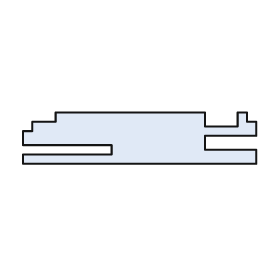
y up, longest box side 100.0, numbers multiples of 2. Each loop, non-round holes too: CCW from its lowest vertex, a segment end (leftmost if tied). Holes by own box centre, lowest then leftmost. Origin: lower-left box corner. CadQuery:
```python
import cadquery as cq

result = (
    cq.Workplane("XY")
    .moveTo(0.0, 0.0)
    .lineTo(100.0, 0.0)
    .lineTo(100.0, 6.0)
    .lineTo(78.0, 6.0)
    .lineTo(78.0, 12.0)
    .lineTo(100.0, 12.0)
    .lineTo(100.0, 18.0)
    .lineTo(96.0, 18.0)
    .lineTo(96.0, 22.0)
    .lineTo(92.0, 22.0)
    .lineTo(92.0, 16.0)
    .lineTo(78.0, 16.0)
    .lineTo(78.0, 22.0)
    .lineTo(14.0, 22.0)
    .lineTo(14.0, 18.0)
    .lineTo(4.0, 18.0)
    .lineTo(4.0, 14.0)
    .lineTo(0.0, 14.0)
    .lineTo(0.0, 8.0)
    .lineTo(38.0, 8.0)
    .lineTo(38.0, 4.0)
    .lineTo(0.0, 4.0)
    .close()
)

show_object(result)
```